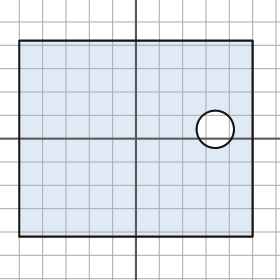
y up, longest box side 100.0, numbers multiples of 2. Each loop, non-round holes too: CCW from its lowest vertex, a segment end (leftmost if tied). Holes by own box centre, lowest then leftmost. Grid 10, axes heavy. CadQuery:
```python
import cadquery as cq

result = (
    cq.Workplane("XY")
    .moveTo(-50.0, -42.0)
    .lineTo(50.0, -42.0)
    .lineTo(50.0, 42.0)
    .lineTo(-50.0, 42.0)
    .close()
    .moveTo(34.0, 4.0)
    .circle(8.0)
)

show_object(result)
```